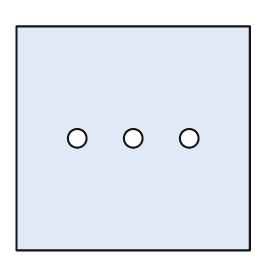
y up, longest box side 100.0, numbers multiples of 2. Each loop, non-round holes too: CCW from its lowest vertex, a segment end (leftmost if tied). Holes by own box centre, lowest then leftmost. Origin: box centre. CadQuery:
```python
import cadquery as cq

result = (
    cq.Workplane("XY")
    .moveTo(-50.0, -48.0)
    .lineTo(50.0, -48.0)
    .lineTo(50.0, 48.0)
    .lineTo(-50.0, 48.0)
    .close()
    .moveTo(-24.0, 0.0)
    .circle(4.0)
    .moveTo(0.0, 0.0)
    .circle(4.0)
    .moveTo(24.0, 0.0)
    .circle(4.0)
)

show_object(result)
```